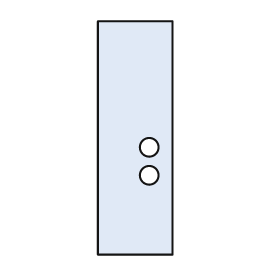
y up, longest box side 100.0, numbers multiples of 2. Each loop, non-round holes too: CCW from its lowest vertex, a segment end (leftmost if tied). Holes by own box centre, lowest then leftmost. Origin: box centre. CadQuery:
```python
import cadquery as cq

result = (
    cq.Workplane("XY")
    .moveTo(-16.0, -50.0)
    .lineTo(16.0, -50.0)
    .lineTo(16.0, 50.0)
    .lineTo(-16.0, 50.0)
    .close()
    .moveTo(6.0, -16.0)
    .circle(4.0)
    .moveTo(6.0, -4.0)
    .circle(4.0)
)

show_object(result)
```